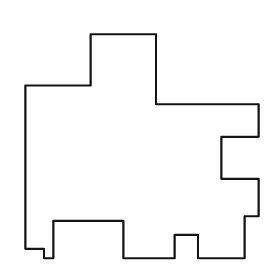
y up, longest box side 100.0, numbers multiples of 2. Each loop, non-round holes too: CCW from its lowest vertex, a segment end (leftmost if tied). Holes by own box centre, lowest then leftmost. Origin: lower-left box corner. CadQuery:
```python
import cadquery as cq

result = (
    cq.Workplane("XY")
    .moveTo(8.0, 0.0)
    .lineTo(12.0, 0.0)
    .lineTo(12.0, 16.0)
    .lineTo(42.0, 16.0)
    .lineTo(42.0, 0.0)
    .lineTo(64.0, 0.0)
    .lineTo(64.0, 10.0)
    .lineTo(74.0, 10.0)
    .lineTo(74.0, 0.0)
    .lineTo(94.0, 0.0)
    .lineTo(94.0, 18.0)
    .lineTo(100.0, 18.0)
    .lineTo(100.0, 34.0)
    .lineTo(84.0, 34.0)
    .lineTo(84.0, 52.0)
    .lineTo(100.0, 52.0)
    .lineTo(100.0, 66.0)
    .lineTo(56.0, 66.0)
    .lineTo(56.0, 96.0)
    .lineTo(28.0, 96.0)
    .lineTo(28.0, 74.0)
    .lineTo(0.0, 74.0)
    .lineTo(0.0, 4.0)
    .lineTo(8.0, 4.0)
    .close()
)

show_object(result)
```